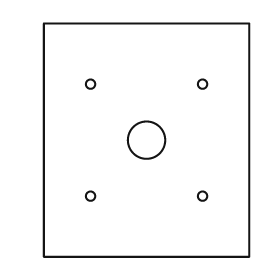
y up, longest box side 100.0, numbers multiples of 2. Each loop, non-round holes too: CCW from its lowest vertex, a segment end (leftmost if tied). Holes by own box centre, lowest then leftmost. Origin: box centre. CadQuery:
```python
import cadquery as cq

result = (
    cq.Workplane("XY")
    .moveTo(-44.0, -50.0)
    .lineTo(44.0, -50.0)
    .lineTo(44.0, 50.0)
    .lineTo(-44.0, 50.0)
    .close()
    .moveTo(-24.0, -24.0)
    .circle(2.0)
    .moveTo(24.0, -24.0)
    .circle(2.0)
    .moveTo(0.0, 0.0)
    .circle(8.0)
    .moveTo(-24.0, 24.0)
    .circle(2.0)
    .moveTo(24.0, 24.0)
    .circle(2.0)
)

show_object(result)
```